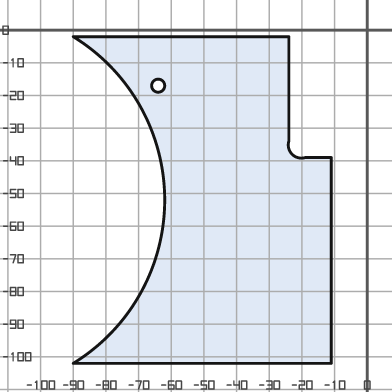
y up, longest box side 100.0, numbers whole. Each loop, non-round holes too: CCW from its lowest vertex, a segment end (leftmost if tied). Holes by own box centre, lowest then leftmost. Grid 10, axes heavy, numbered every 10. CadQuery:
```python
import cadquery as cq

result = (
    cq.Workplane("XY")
    .moveTo(-90.0, -102.0)
    .lineTo(-11.0, -102.0)
    .lineTo(-11.0, -39.0)
    .lineTo(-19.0, -39.0)
    .threePointArc((-23.0, -38.0), (-24.0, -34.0))
    .lineTo(-24.0, -2.0)
    .lineTo(-90.0, -2.0)
    .threePointArc((-62.0, -52.0), (-90.0, -102.0))
    .close()
    .moveTo(-64.0, -17.0)
    .circle(2.0)
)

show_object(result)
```